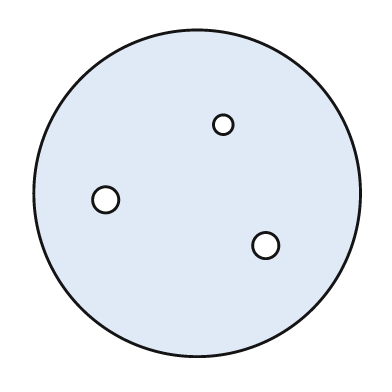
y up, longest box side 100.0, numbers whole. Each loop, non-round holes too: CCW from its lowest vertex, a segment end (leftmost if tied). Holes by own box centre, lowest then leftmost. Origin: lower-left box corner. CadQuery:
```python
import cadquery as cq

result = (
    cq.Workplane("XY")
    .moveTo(50.0, 50.0)
    .circle(50.0)
    .moveTo(71.0, 34.0)
    .circle(4.0)
    .moveTo(22.0, 48.0)
    .circle(4.0)
    .moveTo(58.0, 71.0)
    .circle(3.0)
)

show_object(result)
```